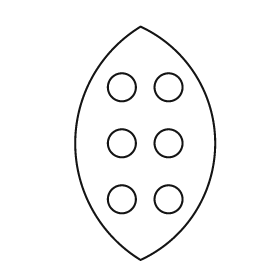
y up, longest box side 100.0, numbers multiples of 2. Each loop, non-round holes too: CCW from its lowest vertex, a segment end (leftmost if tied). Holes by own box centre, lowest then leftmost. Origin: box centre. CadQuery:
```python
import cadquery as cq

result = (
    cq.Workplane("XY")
    .moveTo(-2.0, -50.0)
    .threePointArc((30.0, 0.0), (-2.0, 50.0))
    .threePointArc((-30.0, 0.0), (-2.0, -50.0))
    .close()
    .moveTo(-10.0, -24.0)
    .circle(6.0)
    .moveTo(10.0, -24.0)
    .circle(6.0)
    .moveTo(-10.0, 0.0)
    .circle(6.0)
    .moveTo(10.0, 0.0)
    .circle(6.0)
    .moveTo(-10.0, 24.0)
    .circle(6.0)
    .moveTo(10.0, 24.0)
    .circle(6.0)
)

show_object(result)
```